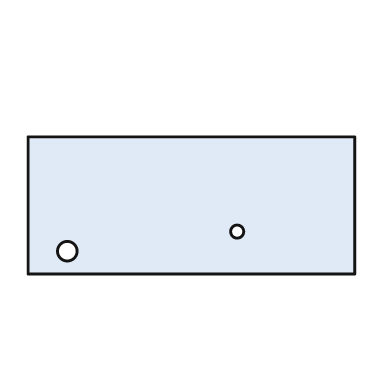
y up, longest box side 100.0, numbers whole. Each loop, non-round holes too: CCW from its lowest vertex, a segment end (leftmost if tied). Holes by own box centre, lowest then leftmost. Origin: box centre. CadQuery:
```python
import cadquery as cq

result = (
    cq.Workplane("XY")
    .moveTo(-50.0, -21.0)
    .lineTo(50.0, -21.0)
    .lineTo(50.0, 21.0)
    .lineTo(-50.0, 21.0)
    .close()
    .moveTo(-38.0, -14.0)
    .circle(3.0)
    .moveTo(14.0, -8.0)
    .circle(2.0)
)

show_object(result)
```